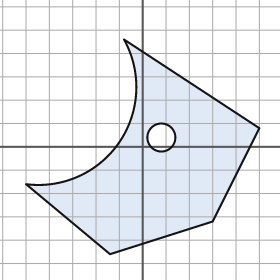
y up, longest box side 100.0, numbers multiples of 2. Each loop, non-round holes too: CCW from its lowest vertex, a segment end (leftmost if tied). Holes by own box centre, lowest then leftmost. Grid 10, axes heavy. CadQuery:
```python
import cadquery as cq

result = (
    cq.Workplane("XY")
    .moveTo(-14.0, -46.0)
    .lineTo(30.0, -32.0)
    .lineTo(50.0, 8.0)
    .lineTo(-8.0, 46.0)
    .threePointArc((-10.0, 2.0), (-50.0, -16.0))
    .close()
    .moveTo(8.0, 4.0)
    .circle(6.0)
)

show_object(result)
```